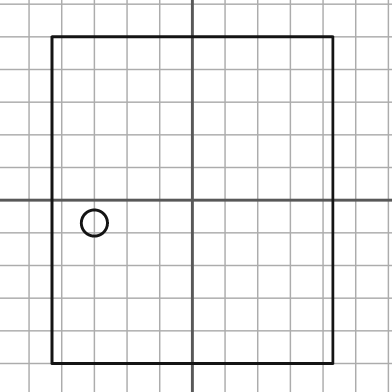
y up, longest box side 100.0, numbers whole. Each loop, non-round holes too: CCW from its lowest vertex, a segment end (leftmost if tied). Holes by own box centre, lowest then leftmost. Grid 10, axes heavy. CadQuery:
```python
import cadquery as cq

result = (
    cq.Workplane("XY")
    .moveTo(-43.0, -50.0)
    .lineTo(43.0, -50.0)
    .lineTo(43.0, 50.0)
    .lineTo(-43.0, 50.0)
    .close()
    .moveTo(-30.0, -7.0)
    .circle(4.0)
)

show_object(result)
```